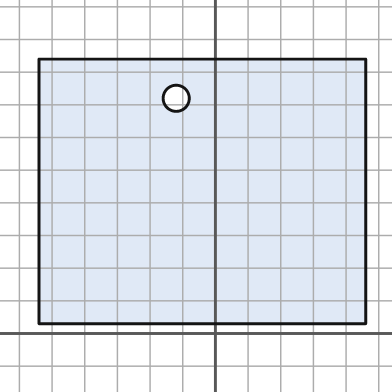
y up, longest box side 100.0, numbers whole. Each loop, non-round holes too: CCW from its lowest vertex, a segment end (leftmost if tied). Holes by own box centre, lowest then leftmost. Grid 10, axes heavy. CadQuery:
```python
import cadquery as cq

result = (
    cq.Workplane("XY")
    .moveTo(-54.0, 3.0)
    .lineTo(46.0, 3.0)
    .lineTo(46.0, 84.0)
    .lineTo(-54.0, 84.0)
    .close()
    .moveTo(-12.0, 72.0)
    .circle(4.0)
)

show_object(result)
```